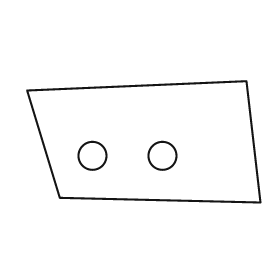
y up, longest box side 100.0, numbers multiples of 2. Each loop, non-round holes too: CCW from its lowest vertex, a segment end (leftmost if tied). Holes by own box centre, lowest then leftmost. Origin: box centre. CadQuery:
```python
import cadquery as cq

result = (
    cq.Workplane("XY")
    .moveTo(50.0, -26.0)
    .lineTo(44.0, 26.0)
    .lineTo(-50.0, 22.0)
    .lineTo(-36.0, -24.0)
    .close()
    .moveTo(-22.0, -6.0)
    .circle(6.0)
    .moveTo(8.0, -6.0)
    .circle(6.0)
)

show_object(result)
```